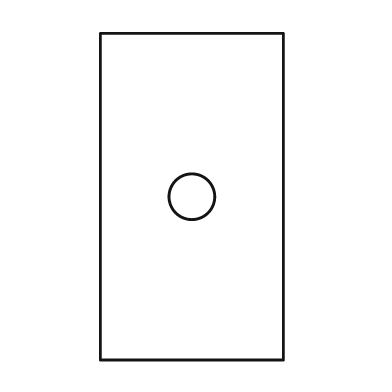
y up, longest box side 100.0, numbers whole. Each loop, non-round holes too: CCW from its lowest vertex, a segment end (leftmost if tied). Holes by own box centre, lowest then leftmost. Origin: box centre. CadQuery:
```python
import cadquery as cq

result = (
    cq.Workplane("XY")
    .moveTo(-28.0, -50.0)
    .lineTo(28.0, -50.0)
    .lineTo(28.0, 50.0)
    .lineTo(-28.0, 50.0)
    .close()
    .moveTo(0.0, 0.0)
    .circle(7.0)
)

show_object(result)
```